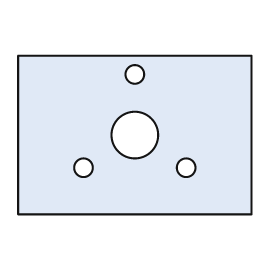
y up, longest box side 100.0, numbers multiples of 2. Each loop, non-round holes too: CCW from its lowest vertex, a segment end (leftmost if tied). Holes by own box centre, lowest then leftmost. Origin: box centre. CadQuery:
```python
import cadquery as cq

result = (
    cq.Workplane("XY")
    .moveTo(-50.0, -34.0)
    .lineTo(50.0, -34.0)
    .lineTo(50.0, 34.0)
    .lineTo(-50.0, 34.0)
    .close()
    .moveTo(-22.0, -14.0)
    .circle(4.0)
    .moveTo(22.0, -14.0)
    .circle(4.0)
    .moveTo(0.0, 0.0)
    .circle(10.0)
    .moveTo(0.0, 26.0)
    .circle(4.0)
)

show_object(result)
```